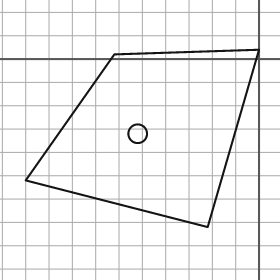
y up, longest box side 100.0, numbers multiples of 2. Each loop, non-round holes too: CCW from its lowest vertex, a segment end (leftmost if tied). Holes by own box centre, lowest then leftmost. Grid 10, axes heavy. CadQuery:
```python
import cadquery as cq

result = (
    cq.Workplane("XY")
    .moveTo(-22.0, -72.0)
    .lineTo(0.0, 4.0)
    .lineTo(-62.0, 2.0)
    .lineTo(-100.0, -52.0)
    .close()
    .moveTo(-52.0, -32.0)
    .circle(4.0)
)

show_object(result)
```